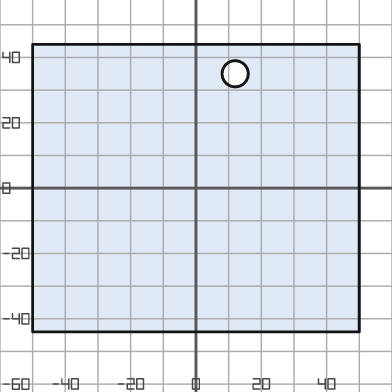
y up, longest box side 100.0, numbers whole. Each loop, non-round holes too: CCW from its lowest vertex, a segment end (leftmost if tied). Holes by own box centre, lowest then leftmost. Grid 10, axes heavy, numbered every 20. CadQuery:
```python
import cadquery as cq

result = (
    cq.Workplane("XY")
    .moveTo(-50.0, -44.0)
    .lineTo(50.0, -44.0)
    .lineTo(50.0, 44.0)
    .lineTo(-50.0, 44.0)
    .close()
    .moveTo(12.0, 35.0)
    .circle(4.0)
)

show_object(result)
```